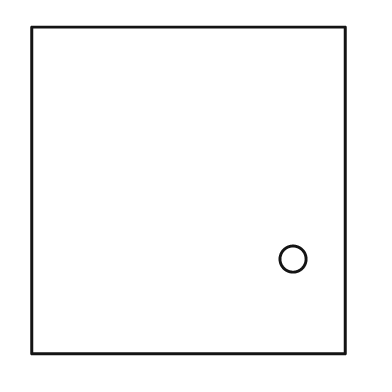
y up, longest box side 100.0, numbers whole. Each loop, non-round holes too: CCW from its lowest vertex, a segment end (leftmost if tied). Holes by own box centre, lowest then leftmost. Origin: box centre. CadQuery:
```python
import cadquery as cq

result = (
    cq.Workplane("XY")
    .moveTo(-48.0, -50.0)
    .lineTo(48.0, -50.0)
    .lineTo(48.0, 50.0)
    .lineTo(-48.0, 50.0)
    .close()
    .moveTo(32.0, -21.0)
    .circle(4.0)
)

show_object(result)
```